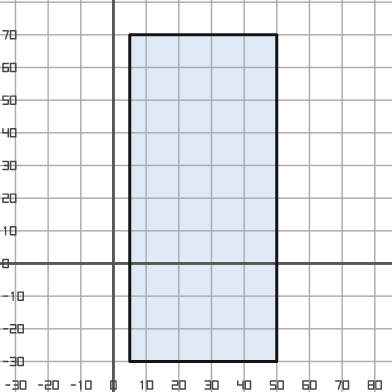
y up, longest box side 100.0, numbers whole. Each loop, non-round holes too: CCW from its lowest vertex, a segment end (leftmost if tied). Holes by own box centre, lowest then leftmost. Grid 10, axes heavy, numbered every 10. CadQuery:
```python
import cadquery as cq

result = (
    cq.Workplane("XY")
    .moveTo(5.0, -30.0)
    .lineTo(50.0, -30.0)
    .lineTo(50.0, 70.0)
    .lineTo(5.0, 70.0)
    .close()
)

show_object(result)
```